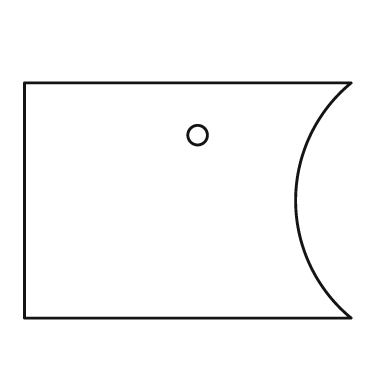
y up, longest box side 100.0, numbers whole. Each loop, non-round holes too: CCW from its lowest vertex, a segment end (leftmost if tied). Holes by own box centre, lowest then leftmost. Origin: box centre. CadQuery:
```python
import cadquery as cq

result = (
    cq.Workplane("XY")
    .moveTo(-50.0, -36.0)
    .lineTo(50.0, -36.0)
    .threePointArc((33.0, 0.0), (50.0, 36.0))
    .lineTo(-50.0, 36.0)
    .close()
    .moveTo(3.0, 20.0)
    .circle(3.0)
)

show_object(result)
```